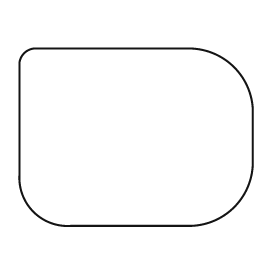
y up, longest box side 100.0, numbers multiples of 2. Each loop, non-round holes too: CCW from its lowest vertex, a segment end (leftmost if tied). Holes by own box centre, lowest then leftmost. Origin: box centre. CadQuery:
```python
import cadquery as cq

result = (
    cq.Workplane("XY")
    .moveTo(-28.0, -38.0)
    .lineTo(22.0, -38.0)
    .threePointArc((42.0, -30.0), (50.0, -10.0))
    .lineTo(50.0, 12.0)
    .threePointArc((42.0, 30.0), (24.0, 38.0))
    .lineTo(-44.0, 38.0)
    .threePointArc((-48.0, 36.0), (-50.0, 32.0))
    .lineTo(-50.0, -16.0)
    .threePointArc((-44.0, -32.0), (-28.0, -38.0))
    .close()
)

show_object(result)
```